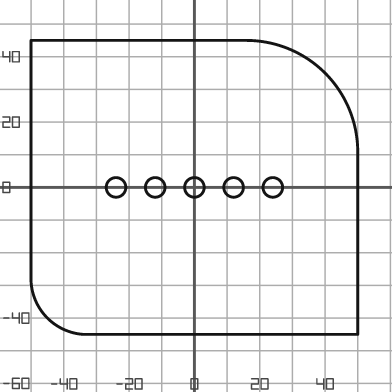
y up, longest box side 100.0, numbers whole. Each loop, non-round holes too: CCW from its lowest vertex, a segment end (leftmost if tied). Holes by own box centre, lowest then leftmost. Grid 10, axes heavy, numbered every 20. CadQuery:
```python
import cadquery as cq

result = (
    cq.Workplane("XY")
    .moveTo(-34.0, -45.0)
    .lineTo(50.0, -45.0)
    .lineTo(50.0, 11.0)
    .threePointArc((40.0, 35.0), (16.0, 45.0))
    .lineTo(-50.0, 45.0)
    .lineTo(-50.0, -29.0)
    .threePointArc((-45.0, -40.0), (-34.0, -45.0))
    .close()
    .moveTo(-24.0, 0.0)
    .circle(3.0)
    .moveTo(-12.0, 0.0)
    .circle(3.0)
    .moveTo(0.0, 0.0)
    .circle(3.0)
    .moveTo(12.0, 0.0)
    .circle(3.0)
    .moveTo(24.0, 0.0)
    .circle(3.0)
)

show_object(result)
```